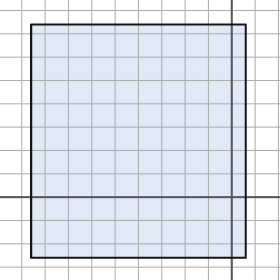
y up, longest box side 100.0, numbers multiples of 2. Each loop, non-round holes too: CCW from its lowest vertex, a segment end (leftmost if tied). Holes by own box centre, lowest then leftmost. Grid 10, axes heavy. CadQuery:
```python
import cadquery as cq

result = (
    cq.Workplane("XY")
    .moveTo(-86.0, -26.0)
    .lineTo(6.0, -26.0)
    .lineTo(6.0, 74.0)
    .lineTo(-86.0, 74.0)
    .close()
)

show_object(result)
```